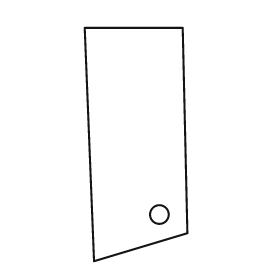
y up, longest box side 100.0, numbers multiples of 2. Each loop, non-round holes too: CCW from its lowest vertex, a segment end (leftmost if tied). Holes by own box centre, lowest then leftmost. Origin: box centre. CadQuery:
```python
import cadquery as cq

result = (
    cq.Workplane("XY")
    .moveTo(-18.0, -50.0)
    .lineTo(22.0, -38.0)
    .lineTo(20.0, 50.0)
    .lineTo(-22.0, 50.0)
    .close()
    .moveTo(10.0, -30.0)
    .circle(4.0)
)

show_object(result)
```